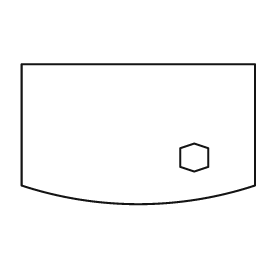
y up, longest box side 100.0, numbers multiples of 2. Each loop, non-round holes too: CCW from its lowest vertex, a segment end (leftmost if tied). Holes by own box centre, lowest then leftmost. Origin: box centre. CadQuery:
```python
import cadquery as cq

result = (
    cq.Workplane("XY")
    .moveTo(-50.0, -22.0)
    .threePointArc((0.0, -30.0), (50.0, -22.0))
    .lineTo(50.0, 30.0)
    .lineTo(-50.0, 30.0)
    .close()
    .moveTo(24.0, -16.0)
    .lineTo(30.0, -14.0)
    .lineTo(30.0, -6.0)
    .lineTo(24.0, -4.0)
    .lineTo(18.0, -6.0)
    .lineTo(18.0, -14.0)
    .close()
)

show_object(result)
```